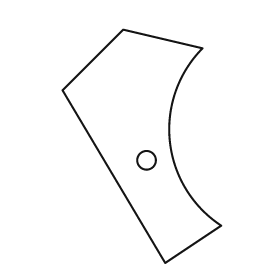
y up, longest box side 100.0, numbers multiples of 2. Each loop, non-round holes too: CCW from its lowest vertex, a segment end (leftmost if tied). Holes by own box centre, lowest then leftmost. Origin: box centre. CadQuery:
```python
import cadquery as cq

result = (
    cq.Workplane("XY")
    .moveTo(10.0, -50.0)
    .lineTo(34.0, -34.0)
    .threePointArc((12.0, 2.0), (26.0, 42.0))
    .lineTo(-8.0, 50.0)
    .lineTo(-34.0, 24.0)
    .close()
    .moveTo(2.0, -6.0)
    .circle(4.0)
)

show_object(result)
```